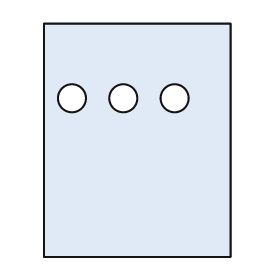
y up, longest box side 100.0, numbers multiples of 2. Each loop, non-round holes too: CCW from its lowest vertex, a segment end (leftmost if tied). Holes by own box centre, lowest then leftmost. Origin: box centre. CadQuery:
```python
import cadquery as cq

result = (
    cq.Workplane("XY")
    .moveTo(-40.0, -50.0)
    .lineTo(40.0, -50.0)
    .lineTo(40.0, 50.0)
    .lineTo(-40.0, 50.0)
    .close()
    .moveTo(-28.0, 18.0)
    .circle(6.0)
    .moveTo(-6.0, 18.0)
    .circle(6.0)
    .moveTo(16.0, 18.0)
    .circle(6.0)
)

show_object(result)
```